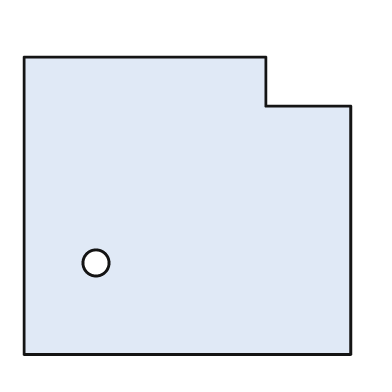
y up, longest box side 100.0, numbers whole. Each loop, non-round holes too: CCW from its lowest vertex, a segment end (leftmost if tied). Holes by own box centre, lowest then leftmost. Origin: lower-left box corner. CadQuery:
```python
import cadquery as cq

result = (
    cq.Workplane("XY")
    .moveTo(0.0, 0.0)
    .lineTo(100.0, 0.0)
    .lineTo(100.0, 76.0)
    .lineTo(74.0, 76.0)
    .lineTo(74.0, 91.0)
    .lineTo(0.0, 91.0)
    .close()
    .moveTo(22.0, 28.0)
    .circle(4.0)
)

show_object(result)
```